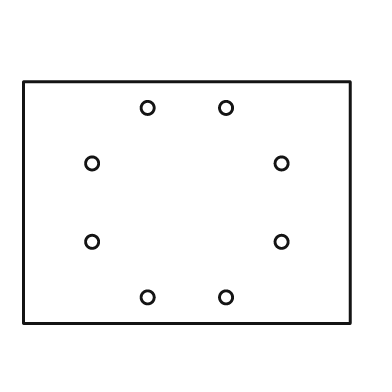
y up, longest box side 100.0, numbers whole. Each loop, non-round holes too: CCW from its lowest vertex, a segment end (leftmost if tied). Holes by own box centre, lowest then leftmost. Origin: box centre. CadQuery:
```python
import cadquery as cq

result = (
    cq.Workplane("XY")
    .moveTo(-50.0, -37.0)
    .lineTo(50.0, -37.0)
    .lineTo(50.0, 37.0)
    .lineTo(-50.0, 37.0)
    .close()
    .moveTo(-12.0, -29.0)
    .circle(2.0)
    .moveTo(12.0, -29.0)
    .circle(2.0)
    .moveTo(-29.0, -12.0)
    .circle(2.0)
    .moveTo(29.0, -12.0)
    .circle(2.0)
    .moveTo(-29.0, 12.0)
    .circle(2.0)
    .moveTo(29.0, 12.0)
    .circle(2.0)
    .moveTo(-12.0, 29.0)
    .circle(2.0)
    .moveTo(12.0, 29.0)
    .circle(2.0)
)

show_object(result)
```